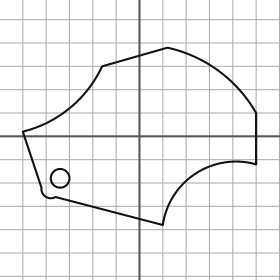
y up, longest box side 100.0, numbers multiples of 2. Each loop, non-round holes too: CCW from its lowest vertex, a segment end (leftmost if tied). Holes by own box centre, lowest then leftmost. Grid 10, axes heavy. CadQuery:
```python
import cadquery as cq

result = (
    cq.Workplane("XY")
    .moveTo(10.0, -38.0)
    .threePointArc((24.0, -16.0), (50.0, -12.0))
    .lineTo(50.0, 10.0)
    .threePointArc((34.0, 28.0), (12.0, 38.0))
    .lineTo(-16.0, 30.0)
    .threePointArc((-30.0, 12.0), (-50.0, 2.0))
    .lineTo(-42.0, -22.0)
    .threePointArc((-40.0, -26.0), (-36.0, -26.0))
    .close()
    .moveTo(-34.0, -18.0)
    .circle(4.0)
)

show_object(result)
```